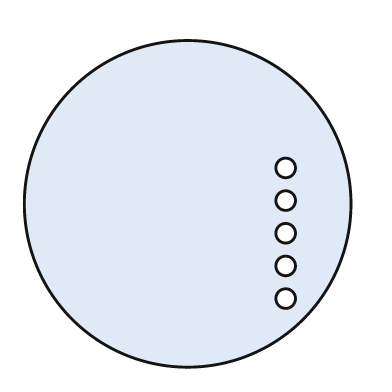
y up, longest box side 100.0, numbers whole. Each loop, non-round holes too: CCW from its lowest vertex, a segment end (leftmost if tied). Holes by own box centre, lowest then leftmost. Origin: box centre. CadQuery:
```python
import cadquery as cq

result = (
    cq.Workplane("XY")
    .moveTo(0.0, 0.0)
    .circle(50.0)
    .moveTo(30.0, -29.0)
    .circle(3.0)
    .moveTo(30.0, -19.0)
    .circle(3.0)
    .moveTo(30.0, -9.0)
    .circle(3.0)
    .moveTo(30.0, 1.0)
    .circle(3.0)
    .moveTo(30.0, 11.0)
    .circle(3.0)
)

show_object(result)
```